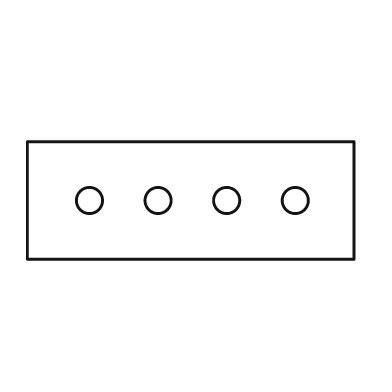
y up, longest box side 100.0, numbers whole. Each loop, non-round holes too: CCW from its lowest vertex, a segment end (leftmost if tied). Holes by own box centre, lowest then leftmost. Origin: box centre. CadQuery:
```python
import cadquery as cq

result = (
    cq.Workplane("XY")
    .moveTo(-50.0, -18.0)
    .lineTo(50.0, -18.0)
    .lineTo(50.0, 18.0)
    .lineTo(-50.0, 18.0)
    .close()
    .moveTo(-31.0, 0.0)
    .circle(4.0)
    .moveTo(-10.0, 0.0)
    .circle(4.0)
    .moveTo(11.0, 0.0)
    .circle(4.0)
    .moveTo(32.0, 0.0)
    .circle(4.0)
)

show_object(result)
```